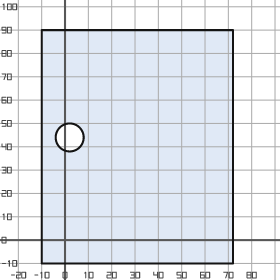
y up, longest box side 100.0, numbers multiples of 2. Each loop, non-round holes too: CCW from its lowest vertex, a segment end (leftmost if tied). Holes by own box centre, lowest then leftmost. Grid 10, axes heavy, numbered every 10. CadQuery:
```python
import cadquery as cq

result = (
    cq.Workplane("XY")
    .moveTo(-10.0, -10.0)
    .lineTo(72.0, -10.0)
    .lineTo(72.0, 90.0)
    .lineTo(-10.0, 90.0)
    .close()
    .moveTo(2.0, 44.0)
    .circle(6.0)
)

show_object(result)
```